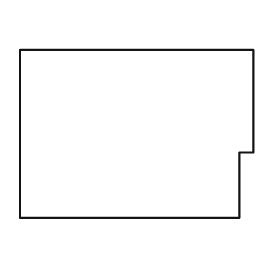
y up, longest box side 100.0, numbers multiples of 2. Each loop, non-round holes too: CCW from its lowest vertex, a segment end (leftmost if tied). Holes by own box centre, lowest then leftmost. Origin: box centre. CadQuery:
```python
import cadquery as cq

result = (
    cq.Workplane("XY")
    .moveTo(-50.0, -36.0)
    .lineTo(44.0, -36.0)
    .lineTo(44.0, -8.0)
    .lineTo(50.0, -8.0)
    .lineTo(50.0, 36.0)
    .lineTo(-50.0, 36.0)
    .close()
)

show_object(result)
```